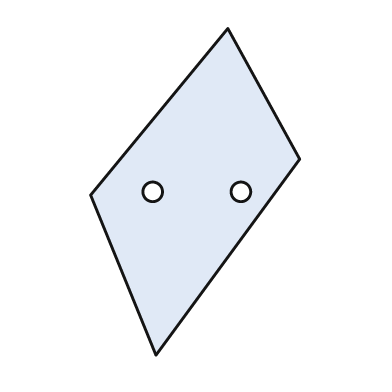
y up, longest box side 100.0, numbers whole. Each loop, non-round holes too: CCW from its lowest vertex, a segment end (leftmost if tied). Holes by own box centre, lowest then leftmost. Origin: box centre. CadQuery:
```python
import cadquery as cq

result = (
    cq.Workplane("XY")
    .moveTo(-12.0, -50.0)
    .lineTo(32.0, 10.0)
    .lineTo(10.0, 50.0)
    .lineTo(-32.0, -1.0)
    .close()
    .moveTo(-13.0, 0.0)
    .circle(3.0)
    .moveTo(14.0, 0.0)
    .circle(3.0)
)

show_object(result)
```